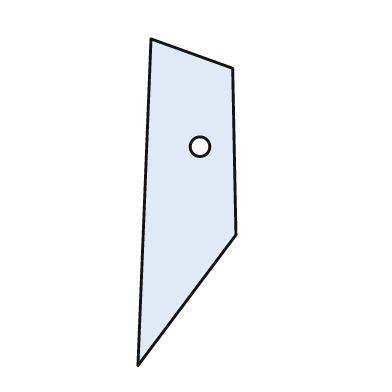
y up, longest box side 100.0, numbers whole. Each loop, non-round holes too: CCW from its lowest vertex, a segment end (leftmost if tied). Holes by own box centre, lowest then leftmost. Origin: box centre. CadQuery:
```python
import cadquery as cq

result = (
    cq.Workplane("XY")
    .moveTo(-15.0, -50.0)
    .lineTo(15.0, -10.0)
    .lineTo(14.0, 41.0)
    .lineTo(-11.0, 50.0)
    .close()
    .moveTo(4.0, 17.0)
    .circle(3.0)
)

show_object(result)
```